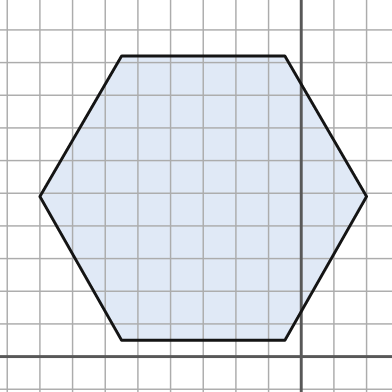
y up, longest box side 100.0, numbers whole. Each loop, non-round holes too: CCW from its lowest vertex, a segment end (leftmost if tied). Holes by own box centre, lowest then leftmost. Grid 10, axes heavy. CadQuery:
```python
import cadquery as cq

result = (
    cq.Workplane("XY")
    .moveTo(-55.0, 5.0)
    .lineTo(-5.0, 5.0)
    .lineTo(20.0, 49.0)
    .lineTo(-5.0, 92.0)
    .lineTo(-55.0, 92.0)
    .lineTo(-80.0, 49.0)
    .close()
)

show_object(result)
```